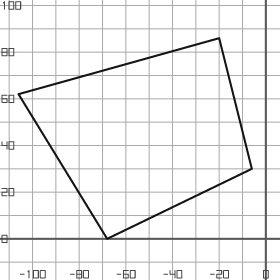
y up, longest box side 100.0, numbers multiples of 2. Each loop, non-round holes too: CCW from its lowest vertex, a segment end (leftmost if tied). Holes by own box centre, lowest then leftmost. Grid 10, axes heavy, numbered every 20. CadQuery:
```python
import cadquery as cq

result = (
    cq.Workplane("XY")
    .moveTo(-68.0, 0.0)
    .lineTo(-6.0, 30.0)
    .lineTo(-20.0, 86.0)
    .lineTo(-106.0, 62.0)
    .close()
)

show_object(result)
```